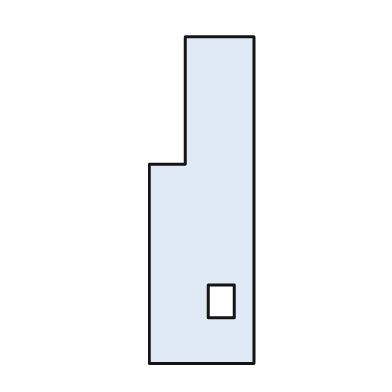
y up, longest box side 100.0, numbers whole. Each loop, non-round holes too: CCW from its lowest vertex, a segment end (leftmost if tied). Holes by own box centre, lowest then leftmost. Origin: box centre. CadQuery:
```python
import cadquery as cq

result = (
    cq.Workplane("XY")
    .moveTo(-16.0, -50.0)
    .lineTo(16.0, -50.0)
    .lineTo(16.0, 50.0)
    .lineTo(-5.0, 50.0)
    .lineTo(-5.0, 11.0)
    .lineTo(-16.0, 11.0)
    .close()
    .moveTo(2.0, -36.0)
    .lineTo(10.0, -36.0)
    .lineTo(10.0, -26.0)
    .lineTo(2.0, -26.0)
    .close()
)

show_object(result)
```